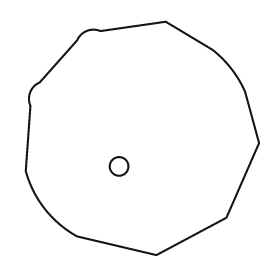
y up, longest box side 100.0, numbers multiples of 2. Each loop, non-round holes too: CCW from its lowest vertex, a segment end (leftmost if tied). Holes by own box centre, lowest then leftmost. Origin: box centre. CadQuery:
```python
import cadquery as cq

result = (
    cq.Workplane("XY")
    .moveTo(6.0, -50.0)
    .lineTo(36.0, -34.0)
    .lineTo(50.0, -2.0)
    .lineTo(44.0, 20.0)
    .threePointArc((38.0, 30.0), (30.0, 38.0))
    .lineTo(10.0, 50.0)
    .lineTo(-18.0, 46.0)
    .threePointArc((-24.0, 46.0), (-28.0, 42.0))
    .lineTo(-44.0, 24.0)
    .threePointArc((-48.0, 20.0), (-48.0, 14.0))
    .lineTo(-50.0, -14.0)
    .threePointArc((-42.0, -30.0), (-28.0, -42.0))
    .close()
    .moveTo(-10.0, -12.0)
    .circle(4.0)
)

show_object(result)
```